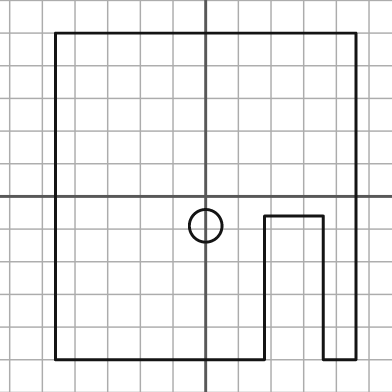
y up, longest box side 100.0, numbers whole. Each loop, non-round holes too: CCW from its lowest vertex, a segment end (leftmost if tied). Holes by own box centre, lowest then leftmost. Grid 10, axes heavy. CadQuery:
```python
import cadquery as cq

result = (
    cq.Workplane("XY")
    .moveTo(-46.0, -50.0)
    .lineTo(18.0, -50.0)
    .lineTo(18.0, -6.0)
    .lineTo(36.0, -6.0)
    .lineTo(36.0, -50.0)
    .lineTo(46.0, -50.0)
    .lineTo(46.0, 50.0)
    .lineTo(-46.0, 50.0)
    .close()
    .moveTo(0.0, -9.0)
    .circle(5.0)
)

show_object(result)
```